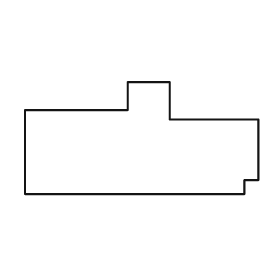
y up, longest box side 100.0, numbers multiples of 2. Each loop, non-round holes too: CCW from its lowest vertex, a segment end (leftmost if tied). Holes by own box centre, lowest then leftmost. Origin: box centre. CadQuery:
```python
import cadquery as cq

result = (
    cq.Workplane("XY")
    .moveTo(-50.0, -24.0)
    .lineTo(44.0, -24.0)
    .lineTo(44.0, -18.0)
    .lineTo(50.0, -18.0)
    .lineTo(50.0, 8.0)
    .lineTo(12.0, 8.0)
    .lineTo(12.0, 24.0)
    .lineTo(-6.0, 24.0)
    .lineTo(-6.0, 12.0)
    .lineTo(-50.0, 12.0)
    .close()
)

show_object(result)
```